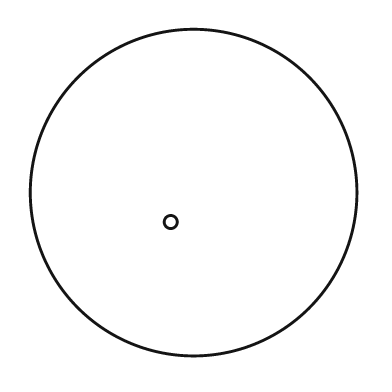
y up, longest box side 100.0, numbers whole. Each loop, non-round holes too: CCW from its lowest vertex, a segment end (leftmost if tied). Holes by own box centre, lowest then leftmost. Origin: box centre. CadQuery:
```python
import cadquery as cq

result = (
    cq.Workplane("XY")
    .moveTo(0.0, 0.0)
    .circle(50.0)
    .moveTo(-7.0, -9.0)
    .circle(2.0)
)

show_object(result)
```